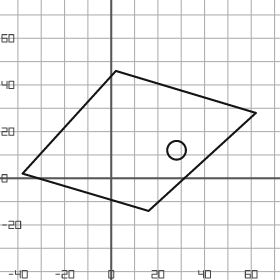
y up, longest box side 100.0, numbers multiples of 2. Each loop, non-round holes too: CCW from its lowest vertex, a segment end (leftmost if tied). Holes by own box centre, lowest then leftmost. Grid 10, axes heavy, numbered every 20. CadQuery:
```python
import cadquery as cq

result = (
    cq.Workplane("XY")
    .moveTo(16.0, -14.0)
    .lineTo(62.0, 28.0)
    .lineTo(2.0, 46.0)
    .lineTo(-38.0, 2.0)
    .close()
    .moveTo(28.0, 12.0)
    .circle(4.0)
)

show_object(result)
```